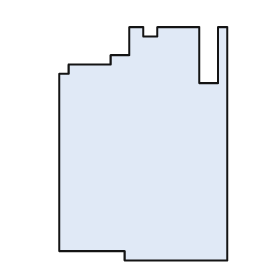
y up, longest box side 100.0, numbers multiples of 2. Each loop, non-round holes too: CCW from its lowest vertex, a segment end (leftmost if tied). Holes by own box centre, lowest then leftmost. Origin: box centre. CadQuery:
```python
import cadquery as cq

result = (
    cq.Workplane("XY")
    .moveTo(-8.0, -50.0)
    .lineTo(36.0, -50.0)
    .lineTo(36.0, 50.0)
    .lineTo(32.0, 50.0)
    .lineTo(32.0, 26.0)
    .lineTo(24.0, 26.0)
    .lineTo(24.0, 50.0)
    .lineTo(6.0, 50.0)
    .lineTo(6.0, 46.0)
    .lineTo(0.0, 46.0)
    .lineTo(0.0, 50.0)
    .lineTo(-6.0, 50.0)
    .lineTo(-6.0, 38.0)
    .lineTo(-14.0, 38.0)
    .lineTo(-14.0, 34.0)
    .lineTo(-32.0, 34.0)
    .lineTo(-32.0, 30.0)
    .lineTo(-36.0, 30.0)
    .lineTo(-36.0, -46.0)
    .lineTo(-8.0, -46.0)
    .close()
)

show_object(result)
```